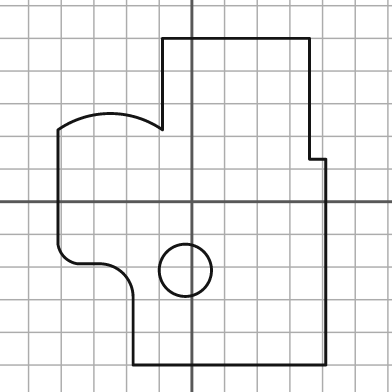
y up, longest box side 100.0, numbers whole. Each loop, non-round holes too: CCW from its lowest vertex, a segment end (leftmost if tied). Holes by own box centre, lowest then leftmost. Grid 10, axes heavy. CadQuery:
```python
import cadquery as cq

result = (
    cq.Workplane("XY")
    .moveTo(-18.0, -50.0)
    .lineTo(41.0, -50.0)
    .lineTo(41.0, 13.0)
    .lineTo(36.0, 13.0)
    .lineTo(36.0, 50.0)
    .lineTo(-9.0, 50.0)
    .lineTo(-9.0, 22.0)
    .threePointArc((-25.0, 27.0), (-41.0, 22.0))
    .lineTo(-41.0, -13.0)
    .threePointArc((-39.0, -17.0), (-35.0, -19.0))
    .lineTo(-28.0, -19.0)
    .threePointArc((-21.0, -22.0), (-18.0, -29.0))
    .close()
    .moveTo(-2.0, -21.0)
    .circle(8.0)
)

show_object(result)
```